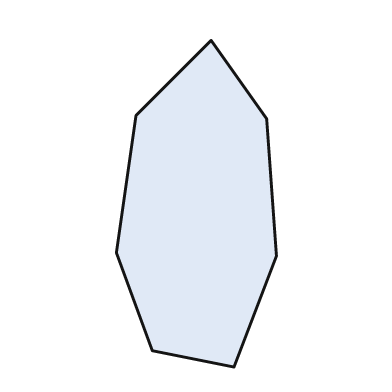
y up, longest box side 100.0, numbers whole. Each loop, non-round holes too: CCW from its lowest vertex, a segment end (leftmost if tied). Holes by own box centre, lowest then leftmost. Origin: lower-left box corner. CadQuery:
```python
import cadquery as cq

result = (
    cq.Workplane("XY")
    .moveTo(36.0, 0.0)
    .lineTo(49.0, 34.0)
    .lineTo(46.0, 76.0)
    .lineTo(29.0, 100.0)
    .lineTo(6.0, 77.0)
    .lineTo(0.0, 35.0)
    .lineTo(11.0, 5.0)
    .close()
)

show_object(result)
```